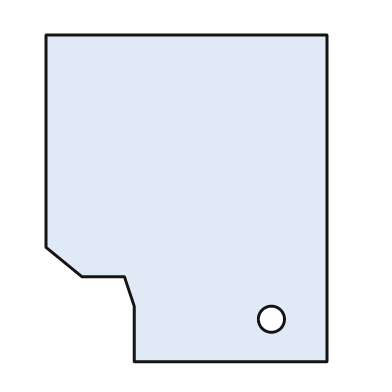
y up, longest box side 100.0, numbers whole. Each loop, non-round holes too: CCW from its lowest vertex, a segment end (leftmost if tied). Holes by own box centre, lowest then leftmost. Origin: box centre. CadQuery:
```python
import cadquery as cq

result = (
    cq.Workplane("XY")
    .moveTo(-16.0, -50.0)
    .lineTo(43.0, -50.0)
    .lineTo(43.0, 50.0)
    .lineTo(-43.0, 50.0)
    .lineTo(-43.0, -15.0)
    .lineTo(-32.0, -24.0)
    .lineTo(-19.0, -24.0)
    .lineTo(-16.0, -33.0)
    .close()
    .moveTo(26.0, -37.0)
    .circle(4.0)
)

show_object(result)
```